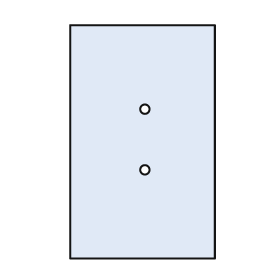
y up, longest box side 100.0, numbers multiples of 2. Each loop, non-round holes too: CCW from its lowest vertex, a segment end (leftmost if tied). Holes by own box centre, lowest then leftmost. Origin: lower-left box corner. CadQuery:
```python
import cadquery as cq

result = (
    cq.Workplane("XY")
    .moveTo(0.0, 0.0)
    .lineTo(62.0, 0.0)
    .lineTo(62.0, 100.0)
    .lineTo(0.0, 100.0)
    .close()
    .moveTo(32.0, 38.0)
    .circle(2.0)
    .moveTo(32.0, 64.0)
    .circle(2.0)
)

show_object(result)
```